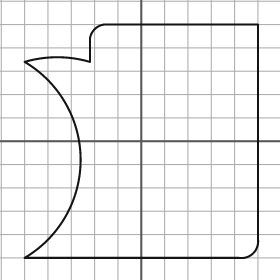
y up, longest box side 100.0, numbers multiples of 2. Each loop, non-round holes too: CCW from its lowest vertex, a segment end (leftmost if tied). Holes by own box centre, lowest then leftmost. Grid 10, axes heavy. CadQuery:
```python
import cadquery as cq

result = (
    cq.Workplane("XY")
    .moveTo(-50.0, -50.0)
    .lineTo(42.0, -50.0)
    .threePointArc((48.0, -48.0), (50.0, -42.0))
    .lineTo(50.0, 50.0)
    .lineTo(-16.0, 50.0)
    .threePointArc((-20.0, 48.0), (-22.0, 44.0))
    .lineTo(-22.0, 34.0)
    .threePointArc((-36.0, 36.0), (-50.0, 34.0))
    .threePointArc((-26.0, -8.0), (-50.0, -50.0))
    .close()
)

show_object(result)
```